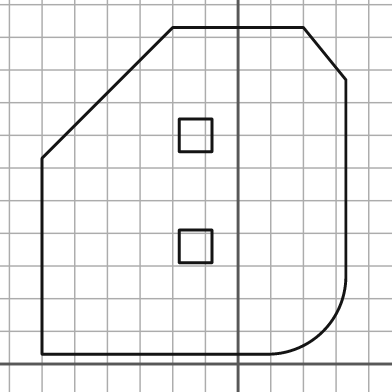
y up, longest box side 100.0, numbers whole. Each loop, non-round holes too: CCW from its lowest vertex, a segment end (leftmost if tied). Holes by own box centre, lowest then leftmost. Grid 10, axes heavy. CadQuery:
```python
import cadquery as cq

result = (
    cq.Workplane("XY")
    .moveTo(-60.0, 3.0)
    .lineTo(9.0, 3.0)
    .threePointArc((26.0, 10.0), (33.0, 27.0))
    .lineTo(33.0, 87.0)
    .lineTo(20.0, 103.0)
    .lineTo(-20.0, 103.0)
    .lineTo(-60.0, 63.0)
    .close()
    .moveTo(-18.0, 31.0)
    .lineTo(-8.0, 31.0)
    .lineTo(-8.0, 41.0)
    .lineTo(-18.0, 41.0)
    .close()
    .moveTo(-18.0, 65.0)
    .lineTo(-8.0, 65.0)
    .lineTo(-8.0, 75.0)
    .lineTo(-18.0, 75.0)
    .close()
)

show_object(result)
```